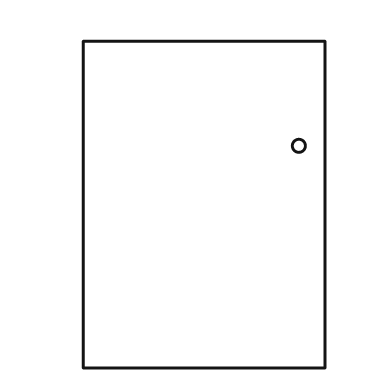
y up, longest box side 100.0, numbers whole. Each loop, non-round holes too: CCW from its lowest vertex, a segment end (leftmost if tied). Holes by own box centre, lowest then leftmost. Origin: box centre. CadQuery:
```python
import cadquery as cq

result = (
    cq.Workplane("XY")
    .moveTo(-37.0, -50.0)
    .lineTo(37.0, -50.0)
    .lineTo(37.0, 50.0)
    .lineTo(-37.0, 50.0)
    .close()
    .moveTo(29.0, 18.0)
    .circle(2.0)
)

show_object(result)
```